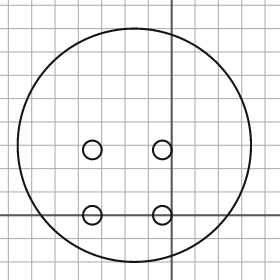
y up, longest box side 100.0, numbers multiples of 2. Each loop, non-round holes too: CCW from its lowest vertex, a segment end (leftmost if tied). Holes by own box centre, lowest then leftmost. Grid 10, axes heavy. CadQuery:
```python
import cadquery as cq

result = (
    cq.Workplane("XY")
    .moveTo(-16.0, 30.0)
    .circle(50.0)
    .moveTo(-34.0, 0.0)
    .circle(4.0)
    .moveTo(-4.0, 0.0)
    .circle(4.0)
    .moveTo(-34.0, 28.0)
    .circle(4.0)
    .moveTo(-4.0, 28.0)
    .circle(4.0)
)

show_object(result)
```